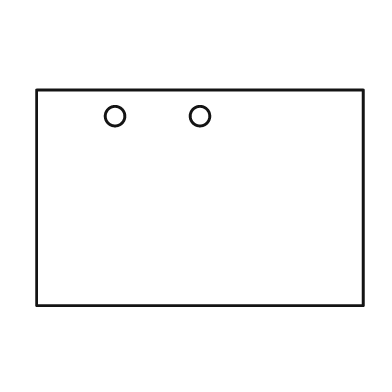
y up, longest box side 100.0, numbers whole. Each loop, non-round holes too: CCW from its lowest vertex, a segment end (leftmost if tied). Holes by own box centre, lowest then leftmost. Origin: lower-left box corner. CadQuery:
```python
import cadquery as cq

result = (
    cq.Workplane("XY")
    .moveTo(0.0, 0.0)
    .lineTo(100.0, 0.0)
    .lineTo(100.0, 66.0)
    .lineTo(0.0, 66.0)
    .close()
    .moveTo(24.0, 58.0)
    .circle(3.0)
    .moveTo(50.0, 58.0)
    .circle(3.0)
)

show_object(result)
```